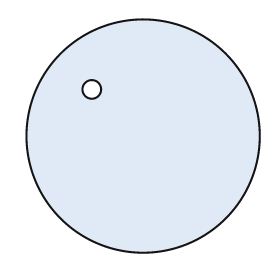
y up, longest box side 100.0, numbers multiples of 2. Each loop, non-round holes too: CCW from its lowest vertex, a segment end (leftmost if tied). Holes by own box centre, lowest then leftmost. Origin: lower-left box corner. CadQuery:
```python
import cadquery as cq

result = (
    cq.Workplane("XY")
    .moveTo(50.0, 50.0)
    .circle(50.0)
    .moveTo(28.0, 70.0)
    .circle(4.0)
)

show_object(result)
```